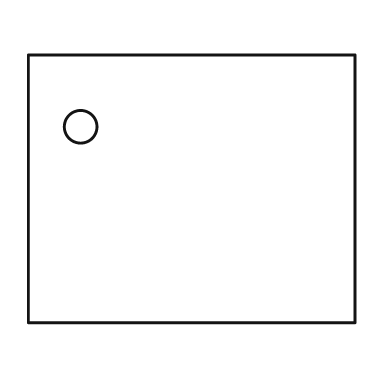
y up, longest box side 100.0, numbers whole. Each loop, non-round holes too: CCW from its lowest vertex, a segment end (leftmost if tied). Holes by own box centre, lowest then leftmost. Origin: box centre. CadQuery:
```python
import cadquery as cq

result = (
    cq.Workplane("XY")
    .moveTo(-50.0, -41.0)
    .lineTo(50.0, -41.0)
    .lineTo(50.0, 41.0)
    .lineTo(-50.0, 41.0)
    .close()
    .moveTo(-34.0, 19.0)
    .circle(5.0)
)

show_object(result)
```